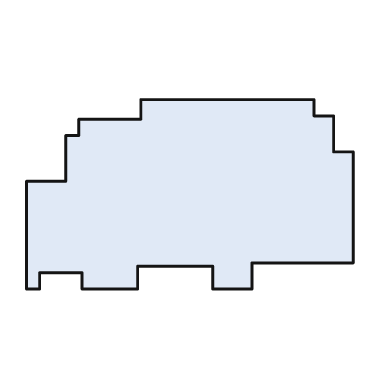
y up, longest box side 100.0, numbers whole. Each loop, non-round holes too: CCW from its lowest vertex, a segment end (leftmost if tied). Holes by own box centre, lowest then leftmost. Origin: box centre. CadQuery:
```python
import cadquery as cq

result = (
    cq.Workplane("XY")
    .moveTo(-50.0, -29.0)
    .lineTo(-46.0, -29.0)
    .lineTo(-46.0, -24.0)
    .lineTo(-33.0, -24.0)
    .lineTo(-33.0, -29.0)
    .lineTo(-16.0, -29.0)
    .lineTo(-16.0, -22.0)
    .lineTo(7.0, -22.0)
    .lineTo(7.0, -29.0)
    .lineTo(19.0, -29.0)
    .lineTo(19.0, -21.0)
    .lineTo(50.0, -21.0)
    .lineTo(50.0, 13.0)
    .lineTo(44.0, 13.0)
    .lineTo(44.0, 24.0)
    .lineTo(38.0, 24.0)
    .lineTo(38.0, 29.0)
    .lineTo(-15.0, 29.0)
    .lineTo(-15.0, 23.0)
    .lineTo(-34.0, 23.0)
    .lineTo(-34.0, 18.0)
    .lineTo(-38.0, 18.0)
    .lineTo(-38.0, 4.0)
    .lineTo(-50.0, 4.0)
    .close()
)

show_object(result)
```